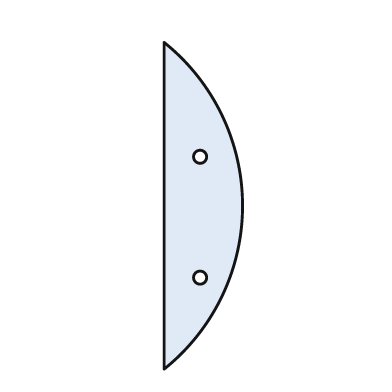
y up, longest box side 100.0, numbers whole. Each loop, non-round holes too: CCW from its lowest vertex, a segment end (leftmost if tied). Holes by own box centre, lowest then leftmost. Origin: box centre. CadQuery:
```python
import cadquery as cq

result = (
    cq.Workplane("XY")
    .moveTo(-12.0, -50.0)
    .threePointArc((12.0, 0.0), (-12.0, 50.0))
    .close()
    .moveTo(-1.0, -22.0)
    .circle(2.0)
    .moveTo(-1.0, 15.0)
    .circle(2.0)
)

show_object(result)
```